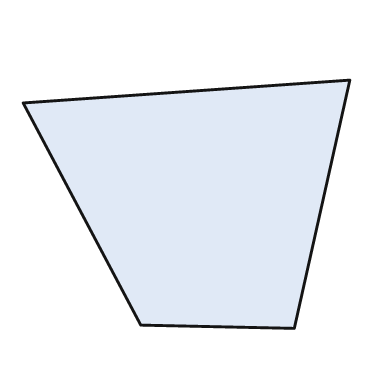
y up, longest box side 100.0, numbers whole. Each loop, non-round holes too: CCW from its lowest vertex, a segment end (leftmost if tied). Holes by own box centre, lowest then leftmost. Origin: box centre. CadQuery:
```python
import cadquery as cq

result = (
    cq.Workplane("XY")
    .moveTo(33.0, -38.0)
    .lineTo(50.0, 38.0)
    .lineTo(-50.0, 31.0)
    .lineTo(-14.0, -37.0)
    .close()
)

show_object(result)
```